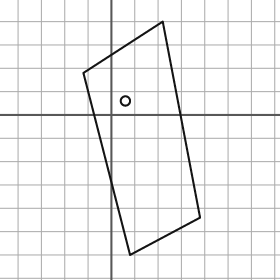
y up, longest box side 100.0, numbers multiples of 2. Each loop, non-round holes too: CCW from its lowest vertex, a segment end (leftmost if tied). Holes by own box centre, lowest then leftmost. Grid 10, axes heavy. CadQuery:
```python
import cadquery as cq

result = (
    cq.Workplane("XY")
    .moveTo(8.0, -60.0)
    .lineTo(38.0, -44.0)
    .lineTo(22.0, 40.0)
    .lineTo(-12.0, 18.0)
    .close()
    .moveTo(6.0, 6.0)
    .circle(2.0)
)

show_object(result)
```